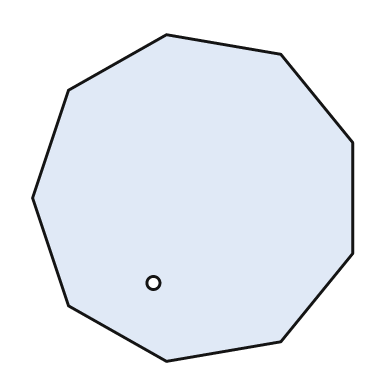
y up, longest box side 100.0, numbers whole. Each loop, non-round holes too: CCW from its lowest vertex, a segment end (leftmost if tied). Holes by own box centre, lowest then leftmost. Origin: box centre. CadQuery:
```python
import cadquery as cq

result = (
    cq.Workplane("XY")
    .moveTo(-8.0, -50.0)
    .lineTo(27.0, -44.0)
    .lineTo(49.0, -17.0)
    .lineTo(49.0, 17.0)
    .lineTo(27.0, 44.0)
    .lineTo(-8.0, 50.0)
    .lineTo(-38.0, 33.0)
    .lineTo(-49.0, 0.0)
    .lineTo(-38.0, -33.0)
    .close()
    .moveTo(-12.0, -26.0)
    .circle(2.0)
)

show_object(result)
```